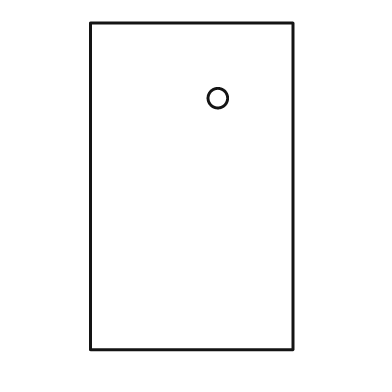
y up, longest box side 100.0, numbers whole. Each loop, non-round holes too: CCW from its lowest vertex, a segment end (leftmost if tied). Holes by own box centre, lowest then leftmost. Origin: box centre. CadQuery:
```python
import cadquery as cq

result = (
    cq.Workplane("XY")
    .moveTo(-31.0, -50.0)
    .lineTo(31.0, -50.0)
    .lineTo(31.0, 50.0)
    .lineTo(-31.0, 50.0)
    .close()
    .moveTo(8.0, 27.0)
    .circle(3.0)
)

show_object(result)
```